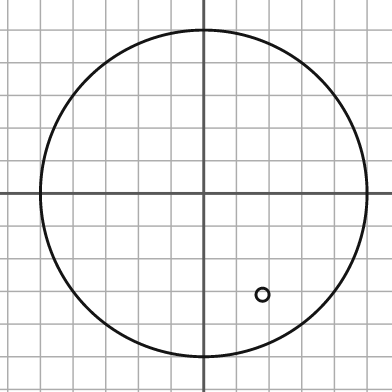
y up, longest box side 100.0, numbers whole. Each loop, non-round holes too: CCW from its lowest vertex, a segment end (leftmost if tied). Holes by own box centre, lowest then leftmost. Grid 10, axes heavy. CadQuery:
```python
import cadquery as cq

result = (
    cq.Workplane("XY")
    .moveTo(0.0, 0.0)
    .circle(50.0)
    .moveTo(18.0, -31.0)
    .circle(2.0)
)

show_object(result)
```